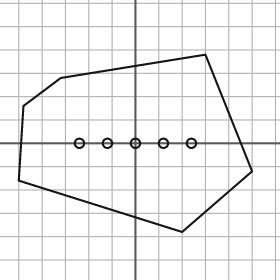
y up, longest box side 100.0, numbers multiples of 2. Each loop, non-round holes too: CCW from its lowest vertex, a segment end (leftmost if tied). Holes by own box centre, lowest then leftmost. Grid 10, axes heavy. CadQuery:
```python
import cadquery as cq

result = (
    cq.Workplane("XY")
    .moveTo(20.0, -38.0)
    .lineTo(50.0, -12.0)
    .lineTo(30.0, 38.0)
    .lineTo(-32.0, 28.0)
    .lineTo(-48.0, 16.0)
    .lineTo(-50.0, -16.0)
    .close()
    .moveTo(-24.0, 0.0)
    .circle(2.0)
    .moveTo(-12.0, 0.0)
    .circle(2.0)
    .moveTo(0.0, 0.0)
    .circle(2.0)
    .moveTo(12.0, 0.0)
    .circle(2.0)
    .moveTo(24.0, 0.0)
    .circle(2.0)
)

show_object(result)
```